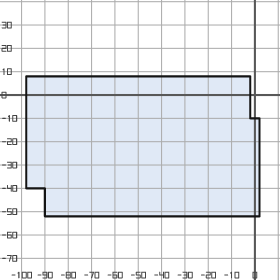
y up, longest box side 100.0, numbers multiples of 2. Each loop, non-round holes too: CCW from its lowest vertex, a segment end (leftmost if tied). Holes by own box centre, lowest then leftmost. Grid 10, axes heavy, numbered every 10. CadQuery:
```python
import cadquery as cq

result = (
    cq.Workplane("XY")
    .moveTo(-90.0, -52.0)
    .lineTo(2.0, -52.0)
    .lineTo(2.0, -10.0)
    .lineTo(-2.0, -10.0)
    .lineTo(-2.0, 8.0)
    .lineTo(-98.0, 8.0)
    .lineTo(-98.0, -40.0)
    .lineTo(-90.0, -40.0)
    .close()
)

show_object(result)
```